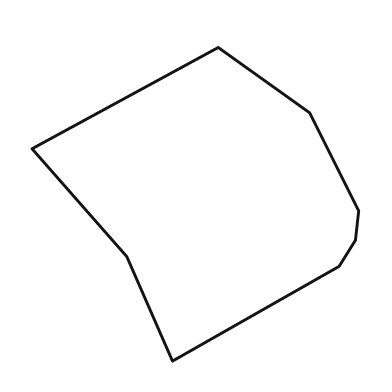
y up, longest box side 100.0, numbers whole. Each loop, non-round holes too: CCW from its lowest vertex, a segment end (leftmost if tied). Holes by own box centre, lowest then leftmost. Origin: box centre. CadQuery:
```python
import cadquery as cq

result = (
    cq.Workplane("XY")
    .moveTo(-7.0, -48.0)
    .lineTo(44.0, -19.0)
    .lineTo(49.0, -11.0)
    .lineTo(50.0, -2.0)
    .lineTo(35.0, 28.0)
    .lineTo(7.0, 48.0)
    .lineTo(-50.0, 17.0)
    .lineTo(-21.0, -16.0)
    .close()
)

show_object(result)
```